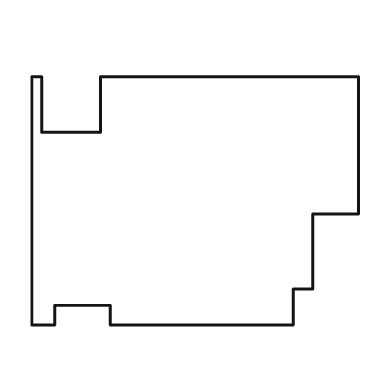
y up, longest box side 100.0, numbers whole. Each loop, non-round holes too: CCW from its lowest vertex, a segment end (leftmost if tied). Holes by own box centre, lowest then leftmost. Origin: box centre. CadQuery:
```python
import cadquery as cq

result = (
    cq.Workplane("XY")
    .moveTo(-50.0, -38.0)
    .lineTo(-43.0, -38.0)
    .lineTo(-43.0, -32.0)
    .lineTo(-26.0, -32.0)
    .lineTo(-26.0, -38.0)
    .lineTo(30.0, -38.0)
    .lineTo(30.0, -27.0)
    .lineTo(36.0, -27.0)
    .lineTo(36.0, -4.0)
    .lineTo(50.0, -4.0)
    .lineTo(50.0, 38.0)
    .lineTo(-29.0, 38.0)
    .lineTo(-29.0, 21.0)
    .lineTo(-47.0, 21.0)
    .lineTo(-47.0, 38.0)
    .lineTo(-50.0, 38.0)
    .close()
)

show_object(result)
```